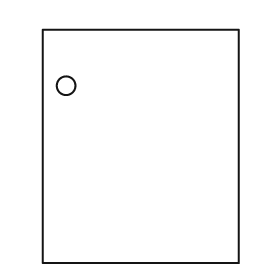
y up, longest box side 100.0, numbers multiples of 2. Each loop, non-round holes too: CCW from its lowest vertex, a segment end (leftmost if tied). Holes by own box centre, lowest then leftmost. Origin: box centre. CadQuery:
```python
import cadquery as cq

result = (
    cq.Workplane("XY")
    .moveTo(-42.0, -50.0)
    .lineTo(42.0, -50.0)
    .lineTo(42.0, 50.0)
    .lineTo(-42.0, 50.0)
    .close()
    .moveTo(-32.0, 26.0)
    .circle(4.0)
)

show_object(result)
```